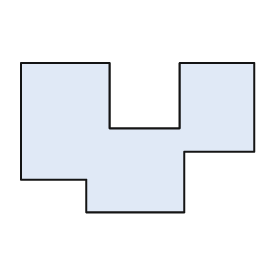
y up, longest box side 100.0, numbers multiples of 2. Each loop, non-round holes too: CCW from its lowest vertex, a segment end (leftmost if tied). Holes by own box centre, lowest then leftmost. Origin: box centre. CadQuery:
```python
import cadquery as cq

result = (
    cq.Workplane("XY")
    .moveTo(-22.0, -32.0)
    .lineTo(20.0, -32.0)
    .lineTo(20.0, -6.0)
    .lineTo(50.0, -6.0)
    .lineTo(50.0, 32.0)
    .lineTo(18.0, 32.0)
    .lineTo(18.0, 4.0)
    .lineTo(-12.0, 4.0)
    .lineTo(-12.0, 32.0)
    .lineTo(-50.0, 32.0)
    .lineTo(-50.0, -18.0)
    .lineTo(-22.0, -18.0)
    .close()
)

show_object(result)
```